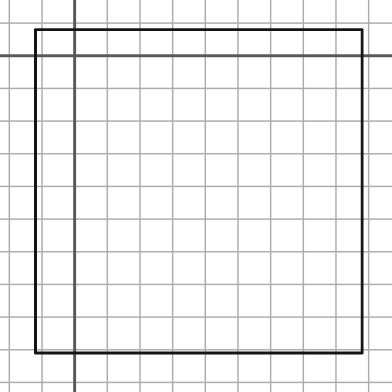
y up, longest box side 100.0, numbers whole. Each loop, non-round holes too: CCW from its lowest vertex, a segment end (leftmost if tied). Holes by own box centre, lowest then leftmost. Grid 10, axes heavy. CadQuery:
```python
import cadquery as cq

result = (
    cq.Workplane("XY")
    .moveTo(-12.0, -91.0)
    .lineTo(88.0, -91.0)
    .lineTo(88.0, 8.0)
    .lineTo(-12.0, 8.0)
    .close()
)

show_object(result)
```